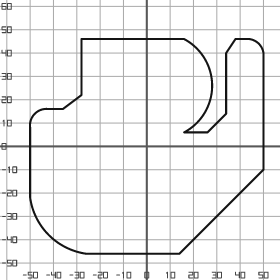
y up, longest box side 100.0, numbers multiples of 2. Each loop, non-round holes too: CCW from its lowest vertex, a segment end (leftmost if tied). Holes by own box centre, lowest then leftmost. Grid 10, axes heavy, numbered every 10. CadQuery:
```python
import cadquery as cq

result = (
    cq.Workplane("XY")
    .moveTo(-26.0, -46.0)
    .lineTo(14.0, -46.0)
    .lineTo(50.0, -10.0)
    .lineTo(50.0, 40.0)
    .threePointArc((48.0, 44.0), (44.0, 46.0))
    .lineTo(38.0, 46.0)
    .lineTo(34.0, 40.0)
    .lineTo(34.0, 14.0)
    .lineTo(26.0, 6.0)
    .lineTo(16.0, 6.0)
    .threePointArc((28.0, 26.0), (16.0, 46.0))
    .lineTo(-28.0, 46.0)
    .lineTo(-28.0, 22.0)
    .lineTo(-36.0, 16.0)
    .lineTo(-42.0, 16.0)
    .threePointArc((-48.0, 14.0), (-50.0, 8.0))
    .lineTo(-50.0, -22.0)
    .threePointArc((-42.0, -38.0), (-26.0, -46.0))
    .close()
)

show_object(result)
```